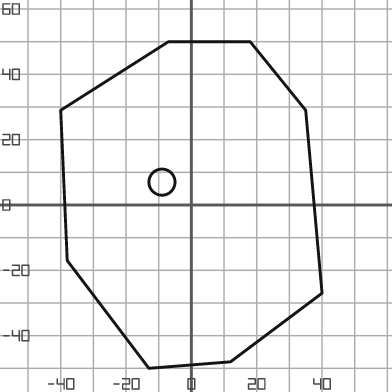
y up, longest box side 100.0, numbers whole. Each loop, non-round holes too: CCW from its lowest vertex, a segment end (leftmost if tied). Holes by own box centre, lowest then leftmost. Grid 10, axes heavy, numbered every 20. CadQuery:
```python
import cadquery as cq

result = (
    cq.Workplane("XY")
    .moveTo(-13.0, -50.0)
    .lineTo(12.0, -48.0)
    .lineTo(40.0, -27.0)
    .lineTo(35.0, 29.0)
    .lineTo(18.0, 50.0)
    .lineTo(-7.0, 50.0)
    .lineTo(-40.0, 29.0)
    .lineTo(-38.0, -17.0)
    .close()
    .moveTo(-9.0, 7.0)
    .circle(4.0)
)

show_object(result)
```